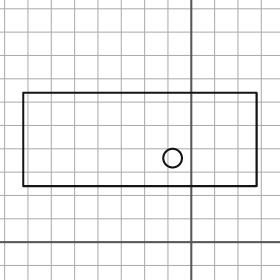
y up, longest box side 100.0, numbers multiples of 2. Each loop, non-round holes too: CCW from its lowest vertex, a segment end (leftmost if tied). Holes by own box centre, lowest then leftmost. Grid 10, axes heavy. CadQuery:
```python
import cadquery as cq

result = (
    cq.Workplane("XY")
    .moveTo(-72.0, 24.0)
    .lineTo(28.0, 24.0)
    .lineTo(28.0, 64.0)
    .lineTo(-72.0, 64.0)
    .close()
    .moveTo(-8.0, 36.0)
    .circle(4.0)
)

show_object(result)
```